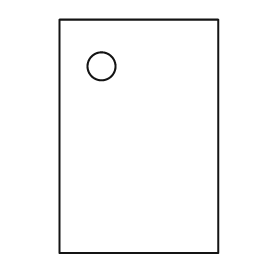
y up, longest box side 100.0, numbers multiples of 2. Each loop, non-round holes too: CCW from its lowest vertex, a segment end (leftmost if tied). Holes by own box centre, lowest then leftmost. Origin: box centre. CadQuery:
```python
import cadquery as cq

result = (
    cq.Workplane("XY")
    .moveTo(-34.0, -50.0)
    .lineTo(34.0, -50.0)
    .lineTo(34.0, 50.0)
    .lineTo(-34.0, 50.0)
    .close()
    .moveTo(-16.0, 30.0)
    .circle(6.0)
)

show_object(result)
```